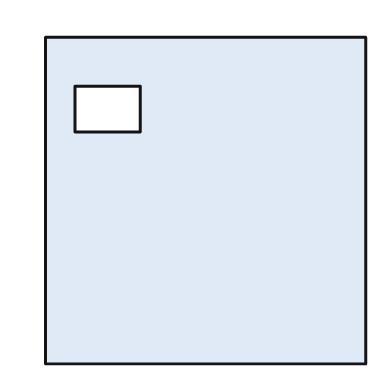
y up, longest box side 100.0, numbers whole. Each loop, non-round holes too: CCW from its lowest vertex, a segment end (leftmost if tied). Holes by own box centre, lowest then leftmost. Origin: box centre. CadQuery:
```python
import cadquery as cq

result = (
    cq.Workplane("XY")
    .moveTo(-49.0, -50.0)
    .lineTo(49.0, -50.0)
    .lineTo(49.0, 50.0)
    .lineTo(-49.0, 50.0)
    .close()
    .moveTo(-40.0, 21.0)
    .lineTo(-20.0, 21.0)
    .lineTo(-20.0, 35.0)
    .lineTo(-40.0, 35.0)
    .close()
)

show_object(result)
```